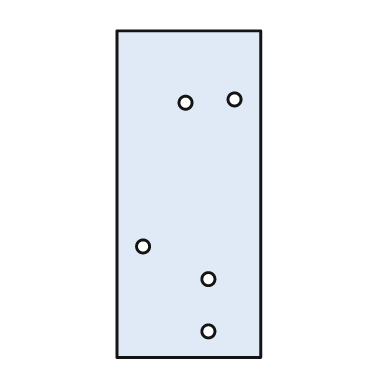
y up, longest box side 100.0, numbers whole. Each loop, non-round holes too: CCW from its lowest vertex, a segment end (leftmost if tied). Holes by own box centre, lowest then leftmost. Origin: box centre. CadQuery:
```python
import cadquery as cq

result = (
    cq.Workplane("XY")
    .moveTo(-22.0, -50.0)
    .lineTo(22.0, -50.0)
    .lineTo(22.0, 50.0)
    .lineTo(-22.0, 50.0)
    .close()
    .moveTo(6.0, -42.0)
    .circle(2.0)
    .moveTo(6.0, -26.0)
    .circle(2.0)
    .moveTo(-14.0, -16.0)
    .circle(2.0)
    .moveTo(-1.0, 28.0)
    .circle(2.0)
    .moveTo(14.0, 29.0)
    .circle(2.0)
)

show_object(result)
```